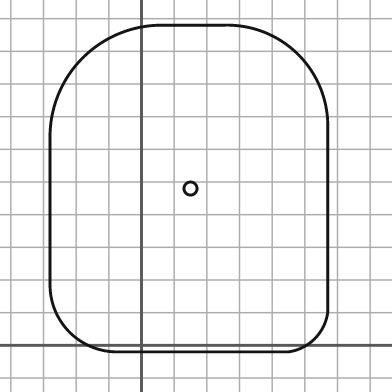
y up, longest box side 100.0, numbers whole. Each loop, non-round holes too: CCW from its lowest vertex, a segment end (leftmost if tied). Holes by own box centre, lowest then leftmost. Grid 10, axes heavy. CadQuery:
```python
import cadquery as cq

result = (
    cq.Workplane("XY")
    .moveTo(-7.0, -2.0)
    .lineTo(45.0, -2.0)
    .threePointArc((53.0, 2.0), (57.0, 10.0))
    .lineTo(57.0, 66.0)
    .threePointArc((48.0, 89.0), (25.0, 98.0))
    .lineTo(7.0, 98.0)
    .threePointArc((-18.0, 88.0), (-28.0, 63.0))
    .lineTo(-28.0, 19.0)
    .threePointArc((-22.0, 4.0), (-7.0, -2.0))
    .close()
    .moveTo(15.0, 48.0)
    .circle(2.0)
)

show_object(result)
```